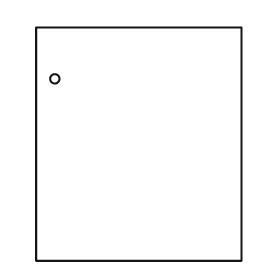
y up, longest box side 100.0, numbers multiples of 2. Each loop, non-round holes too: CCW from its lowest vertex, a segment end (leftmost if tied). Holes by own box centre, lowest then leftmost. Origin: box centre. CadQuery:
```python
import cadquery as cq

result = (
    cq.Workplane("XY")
    .moveTo(-44.0, -50.0)
    .lineTo(44.0, -50.0)
    .lineTo(44.0, 50.0)
    .lineTo(-44.0, 50.0)
    .close()
    .moveTo(-36.0, 28.0)
    .circle(2.0)
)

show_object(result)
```